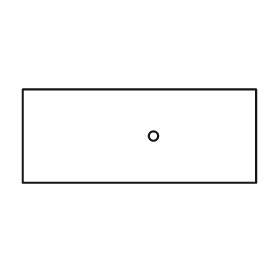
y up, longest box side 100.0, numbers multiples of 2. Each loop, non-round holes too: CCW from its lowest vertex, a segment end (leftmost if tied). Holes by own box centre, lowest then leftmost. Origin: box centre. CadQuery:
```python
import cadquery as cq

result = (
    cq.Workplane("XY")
    .moveTo(-50.0, -20.0)
    .lineTo(50.0, -20.0)
    .lineTo(50.0, 20.0)
    .lineTo(-50.0, 20.0)
    .close()
    .moveTo(6.0, 0.0)
    .circle(2.0)
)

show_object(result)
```